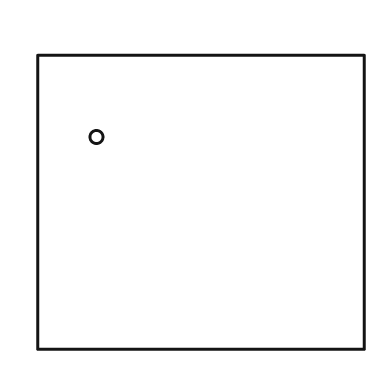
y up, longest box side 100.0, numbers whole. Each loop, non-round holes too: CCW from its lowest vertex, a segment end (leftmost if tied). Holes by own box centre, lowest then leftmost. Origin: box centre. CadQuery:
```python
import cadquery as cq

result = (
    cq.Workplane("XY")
    .moveTo(-50.0, -45.0)
    .lineTo(50.0, -45.0)
    .lineTo(50.0, 45.0)
    .lineTo(-50.0, 45.0)
    .close()
    .moveTo(-32.0, 20.0)
    .circle(2.0)
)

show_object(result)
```